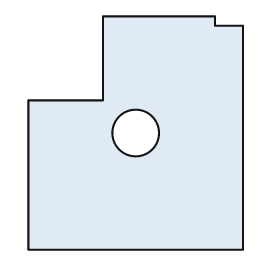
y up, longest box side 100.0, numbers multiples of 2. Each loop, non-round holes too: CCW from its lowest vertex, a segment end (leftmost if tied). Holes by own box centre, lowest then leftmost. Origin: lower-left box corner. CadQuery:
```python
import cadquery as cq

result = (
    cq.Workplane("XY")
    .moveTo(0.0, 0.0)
    .lineTo(92.0, 0.0)
    .lineTo(92.0, 96.0)
    .lineTo(80.0, 96.0)
    .lineTo(80.0, 100.0)
    .lineTo(32.0, 100.0)
    .lineTo(32.0, 64.0)
    .lineTo(0.0, 64.0)
    .close()
    .moveTo(46.0, 50.0)
    .circle(10.0)
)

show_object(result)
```